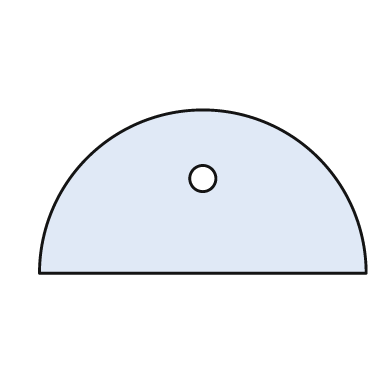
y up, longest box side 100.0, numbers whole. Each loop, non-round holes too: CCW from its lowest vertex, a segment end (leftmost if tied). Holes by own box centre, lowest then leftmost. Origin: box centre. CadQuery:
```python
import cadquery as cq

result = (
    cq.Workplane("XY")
    .moveTo(-50.0, -25.0)
    .lineTo(50.0, -25.0)
    .threePointArc((0.0, 25.0), (-50.0, -25.0))
    .close()
    .moveTo(0.0, 4.0)
    .circle(4.0)
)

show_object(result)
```